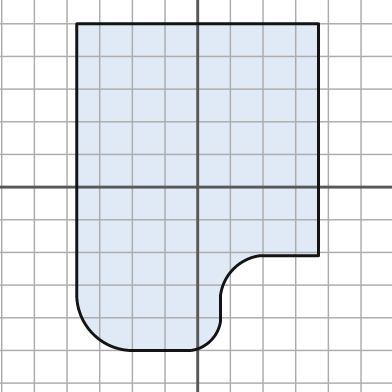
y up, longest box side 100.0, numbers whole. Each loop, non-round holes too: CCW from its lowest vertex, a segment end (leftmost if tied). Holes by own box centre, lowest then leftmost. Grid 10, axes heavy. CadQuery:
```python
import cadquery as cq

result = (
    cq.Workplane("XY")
    .moveTo(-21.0, -50.0)
    .lineTo(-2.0, -50.0)
    .threePointArc((4.0, -47.0), (7.0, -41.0))
    .lineTo(7.0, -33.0)
    .threePointArc((11.0, -25.0), (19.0, -21.0))
    .lineTo(37.0, -21.0)
    .lineTo(37.0, 50.0)
    .lineTo(-37.0, 50.0)
    .lineTo(-37.0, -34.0)
    .threePointArc((-32.0, -45.0), (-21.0, -50.0))
    .close()
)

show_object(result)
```